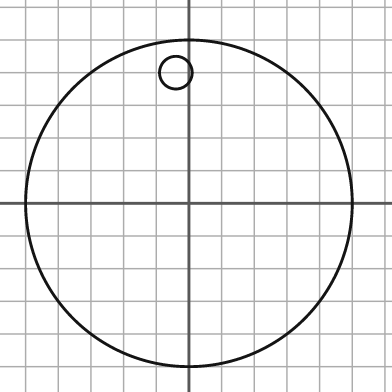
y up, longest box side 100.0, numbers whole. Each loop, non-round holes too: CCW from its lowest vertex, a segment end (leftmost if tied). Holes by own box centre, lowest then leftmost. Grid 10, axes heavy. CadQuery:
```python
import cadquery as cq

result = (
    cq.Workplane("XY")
    .moveTo(0.0, 0.0)
    .circle(50.0)
    .moveTo(-4.0, 40.0)
    .circle(5.0)
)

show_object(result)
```